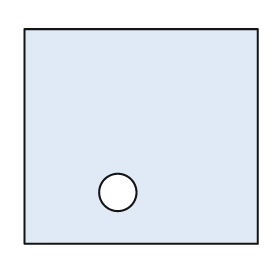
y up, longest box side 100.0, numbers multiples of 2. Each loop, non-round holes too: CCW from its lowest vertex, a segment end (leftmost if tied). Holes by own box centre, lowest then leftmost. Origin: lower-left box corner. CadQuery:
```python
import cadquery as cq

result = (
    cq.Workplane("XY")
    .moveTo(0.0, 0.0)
    .lineTo(100.0, 0.0)
    .lineTo(100.0, 92.0)
    .lineTo(0.0, 92.0)
    .close()
    .moveTo(40.0, 22.0)
    .circle(8.0)
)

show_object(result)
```